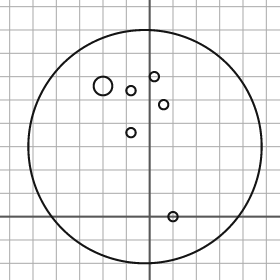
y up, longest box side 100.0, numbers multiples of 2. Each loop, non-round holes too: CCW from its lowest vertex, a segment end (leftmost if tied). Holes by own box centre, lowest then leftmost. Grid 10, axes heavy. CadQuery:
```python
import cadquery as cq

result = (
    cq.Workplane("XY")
    .moveTo(-2.0, 30.0)
    .circle(50.0)
    .moveTo(10.0, 0.0)
    .circle(2.0)
    .moveTo(-8.0, 36.0)
    .circle(2.0)
    .moveTo(6.0, 48.0)
    .circle(2.0)
    .moveTo(-8.0, 54.0)
    .circle(2.0)
    .moveTo(-20.0, 56.0)
    .circle(4.0)
    .moveTo(2.0, 60.0)
    .circle(2.0)
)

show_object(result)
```